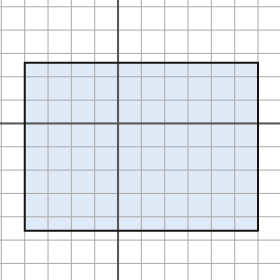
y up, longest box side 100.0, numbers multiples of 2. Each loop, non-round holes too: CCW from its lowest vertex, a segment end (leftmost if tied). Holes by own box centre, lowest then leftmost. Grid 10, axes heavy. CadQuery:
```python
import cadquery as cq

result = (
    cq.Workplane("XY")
    .moveTo(-40.0, -46.0)
    .lineTo(60.0, -46.0)
    .lineTo(60.0, 26.0)
    .lineTo(-40.0, 26.0)
    .close()
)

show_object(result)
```